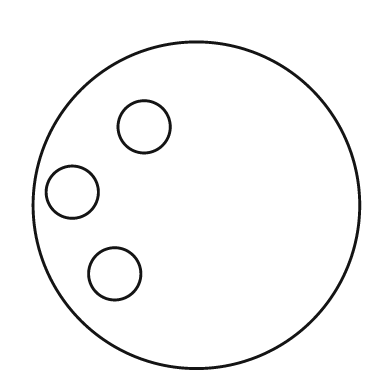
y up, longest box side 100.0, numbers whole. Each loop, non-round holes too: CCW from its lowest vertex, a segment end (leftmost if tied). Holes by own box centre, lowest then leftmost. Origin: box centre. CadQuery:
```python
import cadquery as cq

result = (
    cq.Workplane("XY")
    .moveTo(0.0, 0.0)
    .circle(50.0)
    .moveTo(-25.0, -21.0)
    .circle(8.0)
    .moveTo(-38.0, 4.0)
    .circle(8.0)
    .moveTo(-16.0, 24.0)
    .circle(8.0)
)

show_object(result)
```